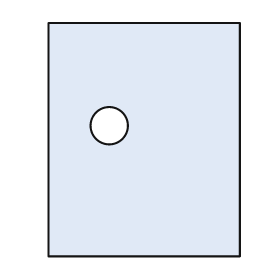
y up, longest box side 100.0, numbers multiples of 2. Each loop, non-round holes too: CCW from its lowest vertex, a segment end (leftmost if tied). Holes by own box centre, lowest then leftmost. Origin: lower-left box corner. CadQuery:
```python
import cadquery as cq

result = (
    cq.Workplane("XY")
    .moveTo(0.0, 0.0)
    .lineTo(82.0, 0.0)
    .lineTo(82.0, 100.0)
    .lineTo(0.0, 100.0)
    .close()
    .moveTo(26.0, 56.0)
    .circle(8.0)
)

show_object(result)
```